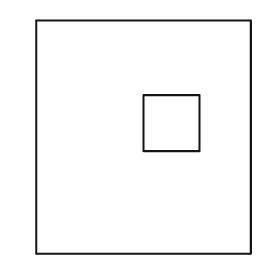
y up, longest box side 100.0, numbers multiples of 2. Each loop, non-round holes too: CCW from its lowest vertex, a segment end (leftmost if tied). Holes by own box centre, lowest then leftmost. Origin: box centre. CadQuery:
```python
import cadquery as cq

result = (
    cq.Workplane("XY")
    .moveTo(-46.0, -50.0)
    .lineTo(46.0, -50.0)
    .lineTo(46.0, 50.0)
    .lineTo(-46.0, 50.0)
    .close()
    .moveTo(0.0, -6.0)
    .lineTo(24.0, -6.0)
    .lineTo(24.0, 18.0)
    .lineTo(0.0, 18.0)
    .close()
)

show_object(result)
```